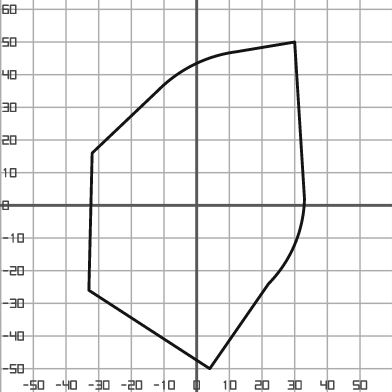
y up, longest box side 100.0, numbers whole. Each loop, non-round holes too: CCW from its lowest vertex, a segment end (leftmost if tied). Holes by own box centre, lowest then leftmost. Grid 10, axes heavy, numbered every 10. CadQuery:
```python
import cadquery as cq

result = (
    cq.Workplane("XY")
    .moveTo(4.0, -50.0)
    .lineTo(22.0, -24.0)
    .threePointArc((30.0, -12.0), (33.0, 2.0))
    .lineTo(30.0, 50.0)
    .lineTo(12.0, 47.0)
    .threePointArc((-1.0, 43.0), (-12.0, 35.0))
    .lineTo(-32.0, 16.0)
    .lineTo(-33.0, -26.0)
    .close()
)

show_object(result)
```